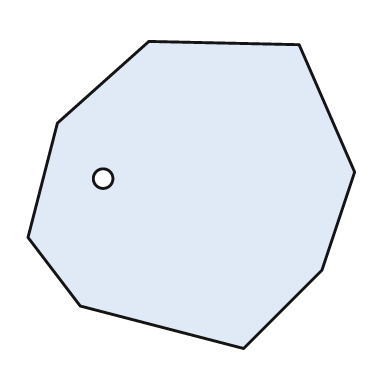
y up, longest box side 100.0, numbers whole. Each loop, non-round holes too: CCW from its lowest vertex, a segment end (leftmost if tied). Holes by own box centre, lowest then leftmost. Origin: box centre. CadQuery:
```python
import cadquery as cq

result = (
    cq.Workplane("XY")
    .moveTo(16.0, -47.0)
    .lineTo(40.0, -23.0)
    .lineTo(50.0, 7.0)
    .lineTo(33.0, 46.0)
    .lineTo(-13.0, 47.0)
    .lineTo(-41.0, 22.0)
    .lineTo(-50.0, -13.0)
    .lineTo(-34.0, -34.0)
    .close()
    .moveTo(-27.0, 5.0)
    .circle(3.0)
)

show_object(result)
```